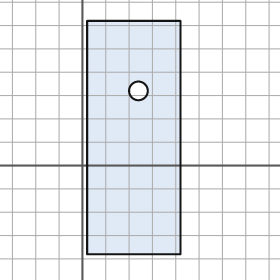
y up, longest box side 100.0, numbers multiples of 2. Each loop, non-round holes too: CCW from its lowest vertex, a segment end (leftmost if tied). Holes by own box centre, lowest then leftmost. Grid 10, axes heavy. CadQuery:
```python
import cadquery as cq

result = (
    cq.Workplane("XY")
    .moveTo(2.0, -38.0)
    .lineTo(42.0, -38.0)
    .lineTo(42.0, 62.0)
    .lineTo(2.0, 62.0)
    .close()
    .moveTo(24.0, 32.0)
    .circle(4.0)
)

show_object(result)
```